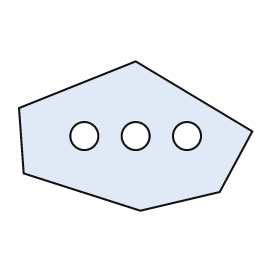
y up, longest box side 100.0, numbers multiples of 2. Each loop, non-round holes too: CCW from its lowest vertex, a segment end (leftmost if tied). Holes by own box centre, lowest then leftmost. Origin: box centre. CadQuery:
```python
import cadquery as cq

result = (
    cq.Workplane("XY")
    .moveTo(2.0, -32.0)
    .lineTo(36.0, -24.0)
    .lineTo(50.0, 2.0)
    .lineTo(0.0, 32.0)
    .lineTo(-50.0, 12.0)
    .lineTo(-48.0, -16.0)
    .close()
    .moveTo(-22.0, 0.0)
    .circle(6.0)
    .moveTo(0.0, 0.0)
    .circle(6.0)
    .moveTo(22.0, 0.0)
    .circle(6.0)
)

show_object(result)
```